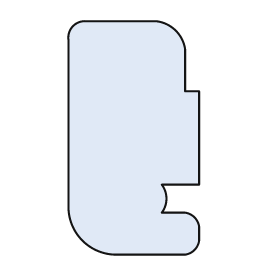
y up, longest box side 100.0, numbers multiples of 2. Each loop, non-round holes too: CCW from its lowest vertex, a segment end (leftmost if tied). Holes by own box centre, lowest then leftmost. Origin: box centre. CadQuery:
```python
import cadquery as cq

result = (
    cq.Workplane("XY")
    .moveTo(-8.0, -50.0)
    .lineTo(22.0, -50.0)
    .threePointArc((26.0, -48.0), (28.0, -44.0))
    .lineTo(28.0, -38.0)
    .threePointArc((26.0, -34.0), (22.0, -32.0))
    .lineTo(12.0, -32.0)
    .threePointArc((14.0, -26.0), (12.0, -20.0))
    .lineTo(28.0, -20.0)
    .lineTo(28.0, 20.0)
    .lineTo(22.0, 20.0)
    .lineTo(22.0, 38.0)
    .threePointArc((18.0, 46.0), (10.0, 50.0))
    .lineTo(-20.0, 50.0)
    .threePointArc((-26.0, 48.0), (-28.0, 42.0))
    .lineTo(-28.0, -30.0)
    .threePointArc((-22.0, -44.0), (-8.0, -50.0))
    .close()
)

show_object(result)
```